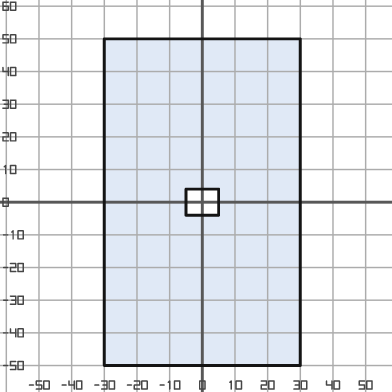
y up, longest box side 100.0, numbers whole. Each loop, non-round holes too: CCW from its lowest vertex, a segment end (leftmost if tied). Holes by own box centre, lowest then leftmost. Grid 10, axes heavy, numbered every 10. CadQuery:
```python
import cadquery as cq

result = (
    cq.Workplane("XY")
    .moveTo(-30.0, -50.0)
    .lineTo(30.0, -50.0)
    .lineTo(30.0, 50.0)
    .lineTo(-30.0, 50.0)
    .close()
    .moveTo(-5.0, -4.0)
    .lineTo(5.0, -4.0)
    .lineTo(5.0, 4.0)
    .lineTo(-5.0, 4.0)
    .close()
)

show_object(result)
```